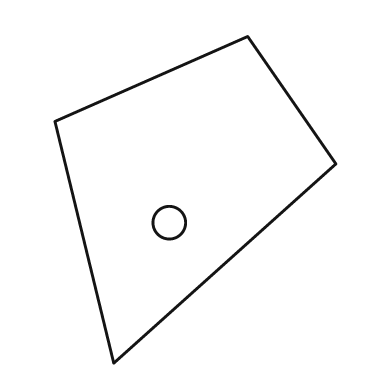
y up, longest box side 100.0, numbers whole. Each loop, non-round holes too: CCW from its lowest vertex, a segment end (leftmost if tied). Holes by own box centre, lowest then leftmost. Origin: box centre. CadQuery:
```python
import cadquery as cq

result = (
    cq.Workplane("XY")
    .moveTo(-25.0, -50.0)
    .lineTo(43.0, 11.0)
    .lineTo(16.0, 50.0)
    .lineTo(-43.0, 24.0)
    .close()
    .moveTo(-8.0, -7.0)
    .circle(5.0)
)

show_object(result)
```